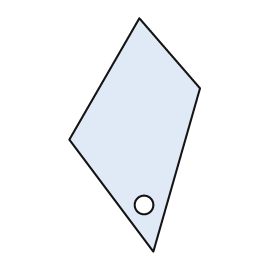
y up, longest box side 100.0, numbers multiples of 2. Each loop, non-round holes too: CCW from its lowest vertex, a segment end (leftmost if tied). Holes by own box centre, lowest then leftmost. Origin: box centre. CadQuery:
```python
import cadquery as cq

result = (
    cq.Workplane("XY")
    .moveTo(8.0, -50.0)
    .lineTo(28.0, 20.0)
    .lineTo(2.0, 50.0)
    .lineTo(-28.0, -2.0)
    .close()
    .moveTo(4.0, -30.0)
    .circle(4.0)
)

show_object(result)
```